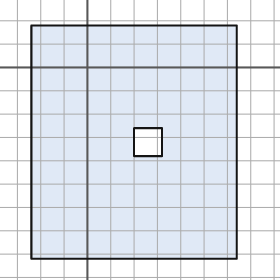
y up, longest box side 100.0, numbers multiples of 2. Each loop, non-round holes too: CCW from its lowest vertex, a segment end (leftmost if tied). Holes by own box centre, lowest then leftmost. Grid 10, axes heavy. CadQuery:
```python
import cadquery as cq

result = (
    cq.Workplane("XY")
    .moveTo(-24.0, -82.0)
    .lineTo(64.0, -82.0)
    .lineTo(64.0, 18.0)
    .lineTo(-24.0, 18.0)
    .close()
    .moveTo(20.0, -38.0)
    .lineTo(32.0, -38.0)
    .lineTo(32.0, -26.0)
    .lineTo(20.0, -26.0)
    .close()
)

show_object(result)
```